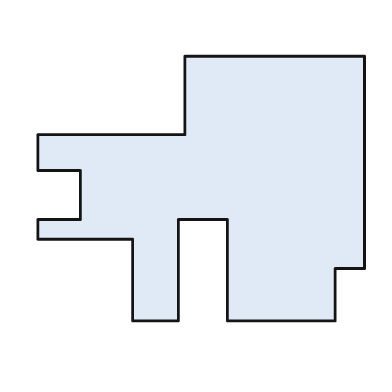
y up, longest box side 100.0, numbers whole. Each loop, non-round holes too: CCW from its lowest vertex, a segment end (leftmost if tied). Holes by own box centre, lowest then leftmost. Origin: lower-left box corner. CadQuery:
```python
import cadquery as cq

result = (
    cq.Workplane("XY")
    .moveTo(29.0, 0.0)
    .lineTo(43.0, 0.0)
    .lineTo(43.0, 31.0)
    .lineTo(58.0, 31.0)
    .lineTo(58.0, 0.0)
    .lineTo(91.0, 0.0)
    .lineTo(91.0, 16.0)
    .lineTo(100.0, 16.0)
    .lineTo(100.0, 81.0)
    .lineTo(45.0, 81.0)
    .lineTo(45.0, 57.0)
    .lineTo(0.0, 57.0)
    .lineTo(0.0, 46.0)
    .lineTo(13.0, 46.0)
    .lineTo(13.0, 31.0)
    .lineTo(0.0, 31.0)
    .lineTo(0.0, 25.0)
    .lineTo(29.0, 25.0)
    .close()
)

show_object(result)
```